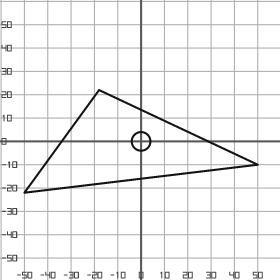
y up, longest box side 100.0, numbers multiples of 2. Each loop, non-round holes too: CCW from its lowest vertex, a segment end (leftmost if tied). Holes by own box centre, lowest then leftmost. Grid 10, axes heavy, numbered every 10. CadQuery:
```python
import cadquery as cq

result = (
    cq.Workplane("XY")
    .moveTo(-50.0, -22.0)
    .lineTo(50.0, -10.0)
    .lineTo(-18.0, 22.0)
    .close()
    .moveTo(0.0, 0.0)
    .circle(4.0)
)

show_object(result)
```